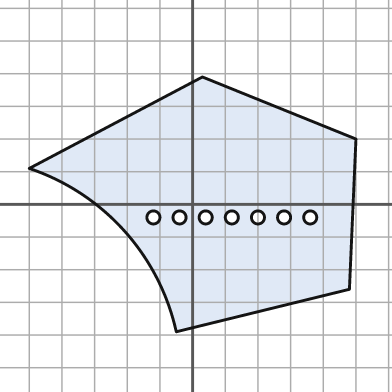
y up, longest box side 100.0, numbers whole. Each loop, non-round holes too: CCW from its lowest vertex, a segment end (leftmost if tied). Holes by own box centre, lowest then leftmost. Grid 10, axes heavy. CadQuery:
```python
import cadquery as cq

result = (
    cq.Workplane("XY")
    .moveTo(-5.0, -39.0)
    .lineTo(48.0, -26.0)
    .lineTo(50.0, 20.0)
    .lineTo(3.0, 39.0)
    .lineTo(-50.0, 11.0)
    .threePointArc((-21.0, -8.0), (-5.0, -39.0))
    .close()
    .moveTo(-12.0, -4.0)
    .circle(2.0)
    .moveTo(-4.0, -4.0)
    .circle(2.0)
    .moveTo(4.0, -4.0)
    .circle(2.0)
    .moveTo(12.0, -4.0)
    .circle(2.0)
    .moveTo(20.0, -4.0)
    .circle(2.0)
    .moveTo(28.0, -4.0)
    .circle(2.0)
    .moveTo(36.0, -4.0)
    .circle(2.0)
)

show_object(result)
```